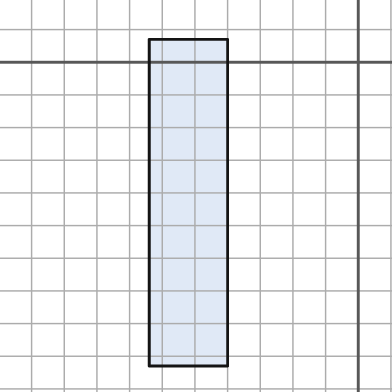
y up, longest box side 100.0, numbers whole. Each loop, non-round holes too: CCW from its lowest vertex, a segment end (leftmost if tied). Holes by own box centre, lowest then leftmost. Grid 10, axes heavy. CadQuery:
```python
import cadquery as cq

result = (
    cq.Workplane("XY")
    .moveTo(-64.0, -93.0)
    .lineTo(-40.0, -93.0)
    .lineTo(-40.0, 7.0)
    .lineTo(-64.0, 7.0)
    .close()
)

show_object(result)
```